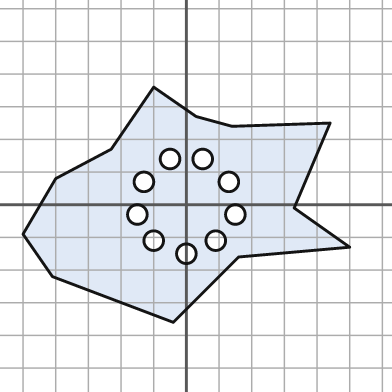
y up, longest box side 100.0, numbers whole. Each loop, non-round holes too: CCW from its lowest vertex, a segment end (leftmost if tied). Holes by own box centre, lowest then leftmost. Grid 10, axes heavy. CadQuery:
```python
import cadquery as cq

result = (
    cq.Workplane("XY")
    .moveTo(-4.0, -36.0)
    .lineTo(16.0, -16.0)
    .lineTo(50.0, -13.0)
    .lineTo(33.0, -1.0)
    .lineTo(44.0, 25.0)
    .lineTo(14.0, 24.0)
    .lineTo(3.0, 27.0)
    .lineTo(-10.0, 36.0)
    .lineTo(-23.0, 17.0)
    .lineTo(-40.0, 8.0)
    .lineTo(-50.0, -9.0)
    .lineTo(-41.0, -22.0)
    .close()
    .moveTo(0.0, -15.0)
    .circle(3.0)
    .moveTo(-10.0, -11.0)
    .circle(3.0)
    .moveTo(9.0, -11.0)
    .circle(3.0)
    .moveTo(-15.0, -3.0)
    .circle(3.0)
    .moveTo(15.0, -3.0)
    .circle(3.0)
    .moveTo(-13.0, 7.0)
    .circle(3.0)
    .moveTo(13.0, 7.0)
    .circle(3.0)
    .moveTo(-5.0, 14.0)
    .circle(3.0)
    .moveTo(5.0, 14.0)
    .circle(3.0)
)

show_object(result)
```